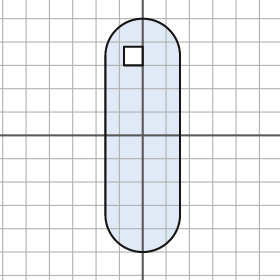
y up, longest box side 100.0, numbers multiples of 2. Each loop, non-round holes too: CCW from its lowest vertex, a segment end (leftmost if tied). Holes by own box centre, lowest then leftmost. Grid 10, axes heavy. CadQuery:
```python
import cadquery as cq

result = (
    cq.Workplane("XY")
    .moveTo(-16.0, -34.0)
    .threePointArc((0.0, -50.0), (16.0, -34.0))
    .lineTo(16.0, 34.0)
    .threePointArc((0.0, 50.0), (-16.0, 34.0))
    .close()
    .moveTo(-8.0, 30.0)
    .lineTo(0.0, 30.0)
    .lineTo(0.0, 38.0)
    .lineTo(-8.0, 38.0)
    .close()
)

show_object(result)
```